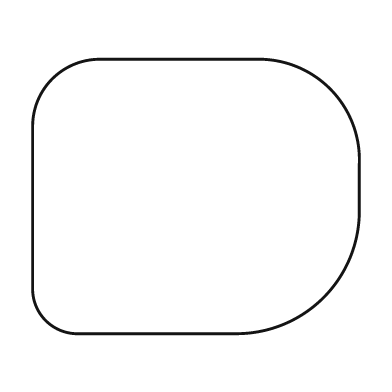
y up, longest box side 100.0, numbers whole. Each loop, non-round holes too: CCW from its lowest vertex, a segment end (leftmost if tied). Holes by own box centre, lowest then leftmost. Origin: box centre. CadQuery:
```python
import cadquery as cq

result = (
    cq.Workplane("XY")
    .moveTo(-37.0, -42.0)
    .lineTo(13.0, -42.0)
    .threePointArc((39.0, -31.0), (50.0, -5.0))
    .lineTo(50.0, 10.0)
    .threePointArc((41.0, 33.0), (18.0, 42.0))
    .lineTo(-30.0, 42.0)
    .threePointArc((-44.0, 36.0), (-50.0, 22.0))
    .lineTo(-50.0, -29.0)
    .threePointArc((-46.0, -38.0), (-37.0, -42.0))
    .close()
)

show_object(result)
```